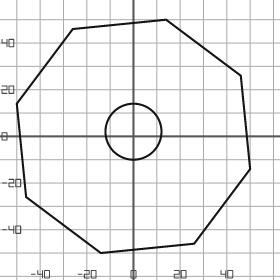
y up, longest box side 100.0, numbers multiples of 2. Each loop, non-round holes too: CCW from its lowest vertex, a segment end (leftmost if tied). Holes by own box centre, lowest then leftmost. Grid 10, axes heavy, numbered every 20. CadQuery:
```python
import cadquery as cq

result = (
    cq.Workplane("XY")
    .moveTo(-14.0, -50.0)
    .lineTo(26.0, -46.0)
    .lineTo(50.0, -14.0)
    .lineTo(46.0, 26.0)
    .lineTo(14.0, 50.0)
    .lineTo(-26.0, 46.0)
    .lineTo(-50.0, 14.0)
    .lineTo(-46.0, -26.0)
    .close()
    .moveTo(0.0, 2.0)
    .circle(12.0)
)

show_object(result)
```